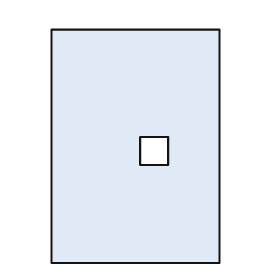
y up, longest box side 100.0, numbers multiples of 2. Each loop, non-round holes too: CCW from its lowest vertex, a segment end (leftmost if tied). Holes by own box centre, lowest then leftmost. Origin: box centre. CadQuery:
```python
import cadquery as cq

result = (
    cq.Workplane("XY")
    .moveTo(-36.0, -50.0)
    .lineTo(36.0, -50.0)
    .lineTo(36.0, 50.0)
    .lineTo(-36.0, 50.0)
    .close()
    .moveTo(2.0, -8.0)
    .lineTo(14.0, -8.0)
    .lineTo(14.0, 4.0)
    .lineTo(2.0, 4.0)
    .close()
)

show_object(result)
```